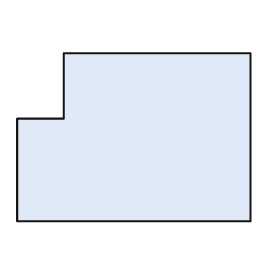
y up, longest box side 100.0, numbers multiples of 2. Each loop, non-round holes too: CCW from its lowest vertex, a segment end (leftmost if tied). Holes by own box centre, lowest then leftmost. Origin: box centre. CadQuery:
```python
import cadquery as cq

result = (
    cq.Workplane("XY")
    .moveTo(-50.0, -36.0)
    .lineTo(50.0, -36.0)
    .lineTo(50.0, 36.0)
    .lineTo(-30.0, 36.0)
    .lineTo(-30.0, 8.0)
    .lineTo(-50.0, 8.0)
    .close()
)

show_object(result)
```